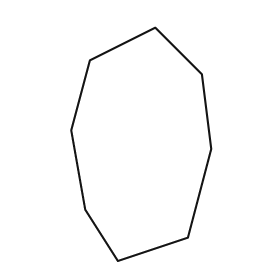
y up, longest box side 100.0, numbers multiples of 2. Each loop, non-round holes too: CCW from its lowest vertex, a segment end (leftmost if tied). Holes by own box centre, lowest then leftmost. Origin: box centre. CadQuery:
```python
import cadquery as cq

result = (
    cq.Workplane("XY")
    .moveTo(-10.0, -50.0)
    .lineTo(20.0, -40.0)
    .lineTo(30.0, -2.0)
    .lineTo(26.0, 30.0)
    .lineTo(6.0, 50.0)
    .lineTo(-22.0, 36.0)
    .lineTo(-30.0, 6.0)
    .lineTo(-24.0, -28.0)
    .close()
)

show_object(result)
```